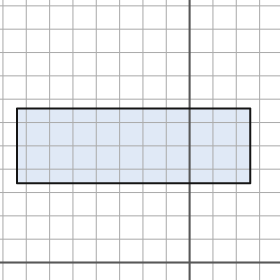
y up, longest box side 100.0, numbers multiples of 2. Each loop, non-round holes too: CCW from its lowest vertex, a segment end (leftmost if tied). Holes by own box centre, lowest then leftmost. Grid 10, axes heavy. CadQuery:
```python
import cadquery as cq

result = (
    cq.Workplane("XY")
    .moveTo(-74.0, 34.0)
    .lineTo(26.0, 34.0)
    .lineTo(26.0, 66.0)
    .lineTo(-74.0, 66.0)
    .close()
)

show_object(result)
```